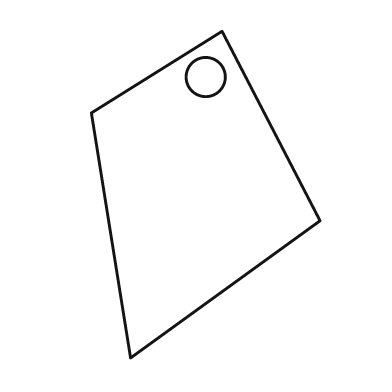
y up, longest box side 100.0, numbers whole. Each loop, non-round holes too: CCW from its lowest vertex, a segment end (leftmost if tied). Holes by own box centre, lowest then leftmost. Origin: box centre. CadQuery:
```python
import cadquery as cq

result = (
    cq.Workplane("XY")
    .moveTo(-23.0, -50.0)
    .lineTo(35.0, -8.0)
    .lineTo(5.0, 50.0)
    .lineTo(-35.0, 25.0)
    .close()
    .moveTo(0.0, 36.0)
    .circle(6.0)
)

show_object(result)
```